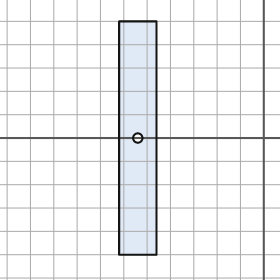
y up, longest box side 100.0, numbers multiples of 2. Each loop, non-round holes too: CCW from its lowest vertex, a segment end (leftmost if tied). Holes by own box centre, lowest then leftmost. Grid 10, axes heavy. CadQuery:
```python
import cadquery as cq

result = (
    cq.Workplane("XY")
    .moveTo(-62.0, -50.0)
    .lineTo(-46.0, -50.0)
    .lineTo(-46.0, 50.0)
    .lineTo(-62.0, 50.0)
    .close()
    .moveTo(-54.0, 0.0)
    .circle(2.0)
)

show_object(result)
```